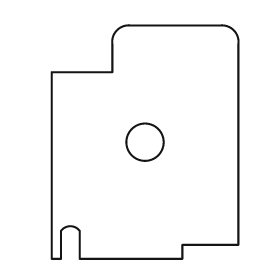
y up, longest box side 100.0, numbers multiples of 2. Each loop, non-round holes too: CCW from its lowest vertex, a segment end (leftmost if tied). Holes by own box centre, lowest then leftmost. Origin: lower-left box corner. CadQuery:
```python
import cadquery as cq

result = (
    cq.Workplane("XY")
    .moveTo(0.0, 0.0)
    .lineTo(4.0, 0.0)
    .lineTo(4.0, 12.0)
    .threePointArc((8.0, 14.0), (12.0, 12.0))
    .lineTo(12.0, 0.0)
    .lineTo(56.0, 0.0)
    .lineTo(56.0, 6.0)
    .lineTo(80.0, 6.0)
    .lineTo(80.0, 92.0)
    .threePointArc((78.0, 98.0), (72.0, 100.0))
    .lineTo(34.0, 100.0)
    .threePointArc((28.0, 98.0), (26.0, 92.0))
    .lineTo(26.0, 80.0)
    .lineTo(0.0, 80.0)
    .close()
    .moveTo(40.0, 50.0)
    .circle(8.0)
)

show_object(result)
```